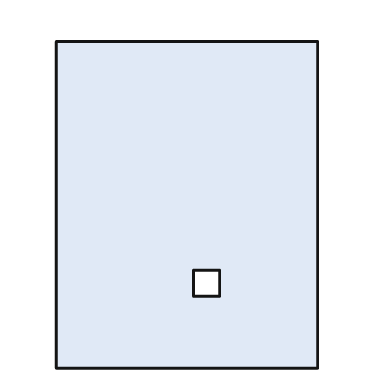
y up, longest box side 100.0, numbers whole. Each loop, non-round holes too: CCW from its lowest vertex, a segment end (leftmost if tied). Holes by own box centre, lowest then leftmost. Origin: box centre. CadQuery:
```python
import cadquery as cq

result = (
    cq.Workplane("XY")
    .moveTo(-40.0, -50.0)
    .lineTo(40.0, -50.0)
    .lineTo(40.0, 50.0)
    .lineTo(-40.0, 50.0)
    .close()
    .moveTo(2.0, -28.0)
    .lineTo(10.0, -28.0)
    .lineTo(10.0, -20.0)
    .lineTo(2.0, -20.0)
    .close()
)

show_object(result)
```